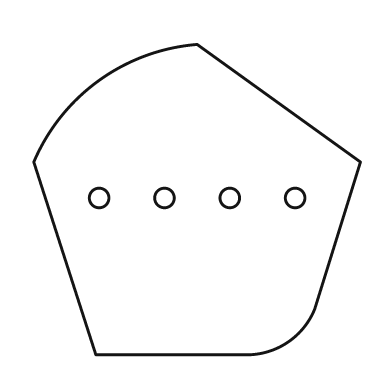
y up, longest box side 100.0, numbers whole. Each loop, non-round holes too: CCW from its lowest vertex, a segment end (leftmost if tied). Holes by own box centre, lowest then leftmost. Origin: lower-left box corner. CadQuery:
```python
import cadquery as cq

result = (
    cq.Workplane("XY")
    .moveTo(19.0, 0.0)
    .lineTo(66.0, 0.0)
    .threePointArc((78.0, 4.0), (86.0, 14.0))
    .lineTo(100.0, 59.0)
    .lineTo(50.0, 95.0)
    .threePointArc((20.0, 84.0), (0.0, 59.0))
    .close()
    .moveTo(20.0, 48.0)
    .circle(3.0)
    .moveTo(40.0, 48.0)
    .circle(3.0)
    .moveTo(60.0, 48.0)
    .circle(3.0)
    .moveTo(80.0, 48.0)
    .circle(3.0)
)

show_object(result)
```